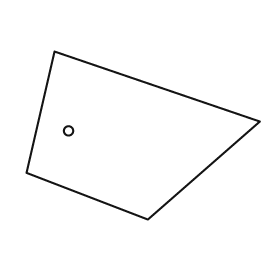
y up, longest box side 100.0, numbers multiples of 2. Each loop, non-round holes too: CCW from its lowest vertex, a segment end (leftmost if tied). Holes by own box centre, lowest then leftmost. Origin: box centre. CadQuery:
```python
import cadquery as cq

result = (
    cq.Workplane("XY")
    .moveTo(2.0, -36.0)
    .lineTo(50.0, 6.0)
    .lineTo(-38.0, 36.0)
    .lineTo(-50.0, -16.0)
    .close()
    .moveTo(-32.0, 2.0)
    .circle(2.0)
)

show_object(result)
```